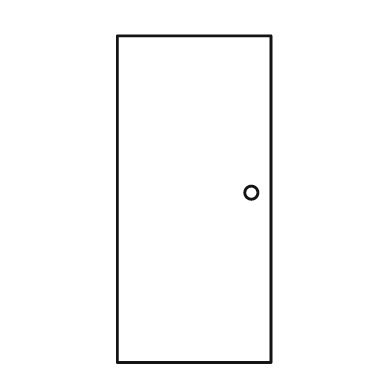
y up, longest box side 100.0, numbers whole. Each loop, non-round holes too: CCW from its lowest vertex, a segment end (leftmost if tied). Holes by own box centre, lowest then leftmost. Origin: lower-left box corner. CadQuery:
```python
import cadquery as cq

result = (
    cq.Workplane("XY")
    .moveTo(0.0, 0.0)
    .lineTo(47.0, 0.0)
    .lineTo(47.0, 100.0)
    .lineTo(0.0, 100.0)
    .close()
    .moveTo(41.0, 52.0)
    .circle(2.0)
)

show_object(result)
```